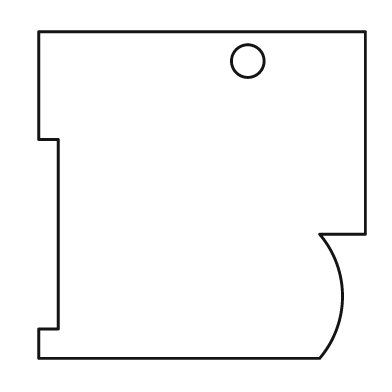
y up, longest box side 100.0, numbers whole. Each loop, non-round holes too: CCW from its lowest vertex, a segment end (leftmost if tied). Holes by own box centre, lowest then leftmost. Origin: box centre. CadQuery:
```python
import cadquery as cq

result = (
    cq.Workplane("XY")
    .moveTo(-50.0, -50.0)
    .lineTo(36.0, -50.0)
    .threePointArc((43.0, -31.0), (36.0, -12.0))
    .lineTo(50.0, -12.0)
    .lineTo(50.0, 50.0)
    .lineTo(-50.0, 50.0)
    .lineTo(-50.0, 17.0)
    .lineTo(-44.0, 17.0)
    .lineTo(-44.0, -41.0)
    .lineTo(-50.0, -41.0)
    .close()
    .moveTo(14.0, 41.0)
    .circle(5.0)
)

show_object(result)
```